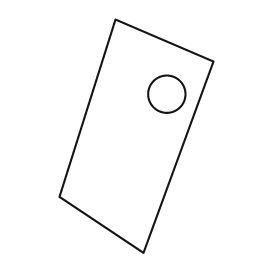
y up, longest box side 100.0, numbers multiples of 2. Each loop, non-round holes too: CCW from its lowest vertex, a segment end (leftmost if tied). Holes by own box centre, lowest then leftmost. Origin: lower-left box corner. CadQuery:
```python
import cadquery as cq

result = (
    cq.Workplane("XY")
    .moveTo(36.0, 0.0)
    .lineTo(66.0, 82.0)
    .lineTo(24.0, 100.0)
    .lineTo(0.0, 24.0)
    .close()
    .moveTo(46.0, 68.0)
    .circle(8.0)
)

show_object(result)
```